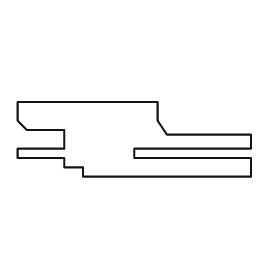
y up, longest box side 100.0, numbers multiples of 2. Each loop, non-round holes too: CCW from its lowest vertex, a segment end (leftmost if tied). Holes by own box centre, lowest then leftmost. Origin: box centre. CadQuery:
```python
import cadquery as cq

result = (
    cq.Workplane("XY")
    .moveTo(-22.0, -16.0)
    .lineTo(50.0, -16.0)
    .lineTo(50.0, -8.0)
    .lineTo(0.0, -8.0)
    .lineTo(0.0, -4.0)
    .lineTo(50.0, -4.0)
    .lineTo(50.0, 2.0)
    .lineTo(14.0, 2.0)
    .lineTo(10.0, 8.0)
    .lineTo(10.0, 16.0)
    .lineTo(-50.0, 16.0)
    .lineTo(-50.0, 8.0)
    .lineTo(-46.0, 4.0)
    .lineTo(-30.0, 4.0)
    .lineTo(-30.0, -4.0)
    .lineTo(-50.0, -4.0)
    .lineTo(-50.0, -8.0)
    .lineTo(-30.0, -8.0)
    .lineTo(-30.0, -12.0)
    .lineTo(-22.0, -12.0)
    .close()
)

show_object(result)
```